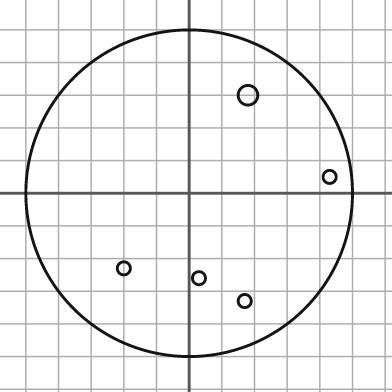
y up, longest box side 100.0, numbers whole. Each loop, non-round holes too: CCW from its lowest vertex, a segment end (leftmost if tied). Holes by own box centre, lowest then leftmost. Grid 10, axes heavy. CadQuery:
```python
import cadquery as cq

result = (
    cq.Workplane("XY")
    .moveTo(0.0, 0.0)
    .circle(50.0)
    .moveTo(17.0, -33.0)
    .circle(2.0)
    .moveTo(3.0, -26.0)
    .circle(2.0)
    .moveTo(-20.0, -23.0)
    .circle(2.0)
    .moveTo(43.0, 5.0)
    .circle(2.0)
    .moveTo(18.0, 30.0)
    .circle(3.0)
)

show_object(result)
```